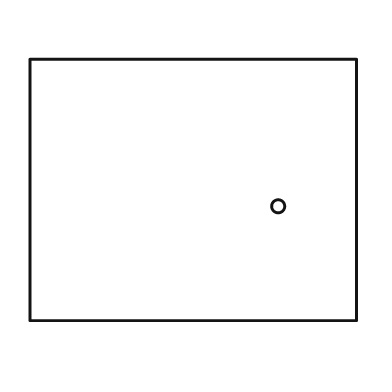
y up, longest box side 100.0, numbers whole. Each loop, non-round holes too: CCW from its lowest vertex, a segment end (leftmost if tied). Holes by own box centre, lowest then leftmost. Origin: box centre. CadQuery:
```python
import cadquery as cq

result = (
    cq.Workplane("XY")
    .moveTo(-50.0, -40.0)
    .lineTo(50.0, -40.0)
    .lineTo(50.0, 40.0)
    .lineTo(-50.0, 40.0)
    .close()
    .moveTo(26.0, -5.0)
    .circle(2.0)
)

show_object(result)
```